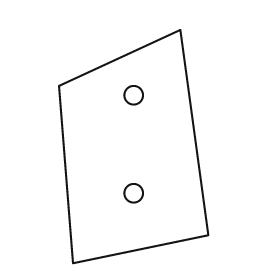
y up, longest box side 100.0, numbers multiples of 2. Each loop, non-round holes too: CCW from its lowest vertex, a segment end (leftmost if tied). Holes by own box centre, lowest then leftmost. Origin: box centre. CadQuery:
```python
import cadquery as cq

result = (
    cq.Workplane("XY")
    .moveTo(-26.0, -50.0)
    .lineTo(32.0, -38.0)
    .lineTo(20.0, 50.0)
    .lineTo(-32.0, 26.0)
    .close()
    .moveTo(0.0, -20.0)
    .circle(4.0)
    .moveTo(0.0, 22.0)
    .circle(4.0)
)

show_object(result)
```